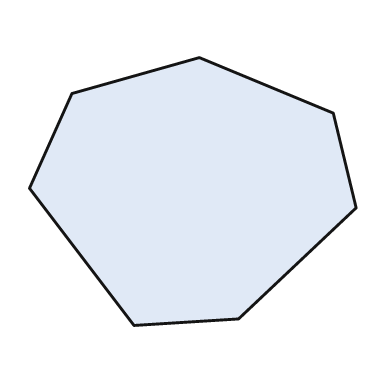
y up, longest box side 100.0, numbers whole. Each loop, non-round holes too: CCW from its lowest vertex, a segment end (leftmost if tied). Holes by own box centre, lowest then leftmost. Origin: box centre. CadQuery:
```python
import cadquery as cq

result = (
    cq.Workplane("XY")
    .moveTo(-18.0, -41.0)
    .lineTo(14.0, -39.0)
    .lineTo(50.0, -5.0)
    .lineTo(43.0, 24.0)
    .lineTo(2.0, 41.0)
    .lineTo(-37.0, 30.0)
    .lineTo(-50.0, 1.0)
    .close()
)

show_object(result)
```